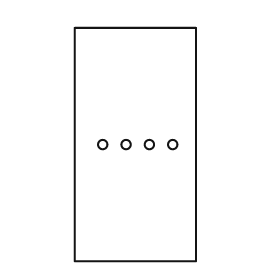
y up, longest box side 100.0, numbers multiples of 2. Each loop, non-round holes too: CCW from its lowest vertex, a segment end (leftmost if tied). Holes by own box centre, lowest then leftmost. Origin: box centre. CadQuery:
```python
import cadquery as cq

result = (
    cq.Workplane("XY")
    .moveTo(-26.0, -50.0)
    .lineTo(26.0, -50.0)
    .lineTo(26.0, 50.0)
    .lineTo(-26.0, 50.0)
    .close()
    .moveTo(-14.0, 0.0)
    .circle(2.0)
    .moveTo(-4.0, 0.0)
    .circle(2.0)
    .moveTo(6.0, 0.0)
    .circle(2.0)
    .moveTo(16.0, 0.0)
    .circle(2.0)
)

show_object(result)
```